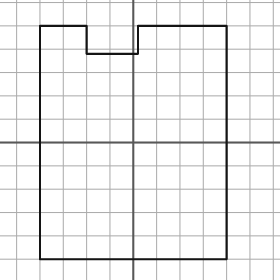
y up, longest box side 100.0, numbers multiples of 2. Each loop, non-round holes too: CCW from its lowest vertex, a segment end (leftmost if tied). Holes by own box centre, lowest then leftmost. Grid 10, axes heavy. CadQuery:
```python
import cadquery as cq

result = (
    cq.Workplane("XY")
    .moveTo(-40.0, -50.0)
    .lineTo(40.0, -50.0)
    .lineTo(40.0, 50.0)
    .lineTo(2.0, 50.0)
    .lineTo(2.0, 38.0)
    .lineTo(-20.0, 38.0)
    .lineTo(-20.0, 50.0)
    .lineTo(-40.0, 50.0)
    .close()
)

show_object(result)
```